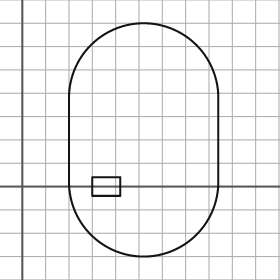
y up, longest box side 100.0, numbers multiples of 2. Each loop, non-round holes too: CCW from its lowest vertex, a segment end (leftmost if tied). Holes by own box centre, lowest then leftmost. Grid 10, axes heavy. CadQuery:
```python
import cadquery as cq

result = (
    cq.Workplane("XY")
    .moveTo(20.0, 2.0)
    .threePointArc((52.0, -30.0), (84.0, 2.0))
    .lineTo(84.0, 38.0)
    .threePointArc((52.0, 70.0), (20.0, 38.0))
    .close()
    .moveTo(30.0, -4.0)
    .lineTo(42.0, -4.0)
    .lineTo(42.0, 4.0)
    .lineTo(30.0, 4.0)
    .close()
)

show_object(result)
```